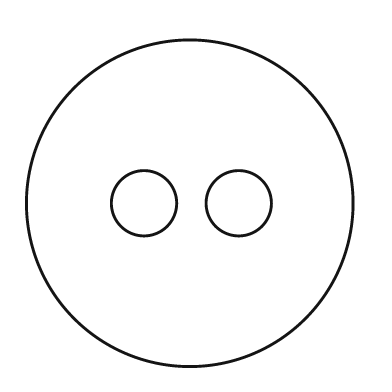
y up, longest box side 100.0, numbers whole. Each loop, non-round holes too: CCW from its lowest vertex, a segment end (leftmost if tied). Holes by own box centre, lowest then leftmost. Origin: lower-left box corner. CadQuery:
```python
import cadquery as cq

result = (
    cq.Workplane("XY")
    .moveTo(50.0, 50.0)
    .circle(50.0)
    .moveTo(36.0, 50.0)
    .circle(10.0)
    .moveTo(65.0, 50.0)
    .circle(10.0)
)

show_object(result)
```